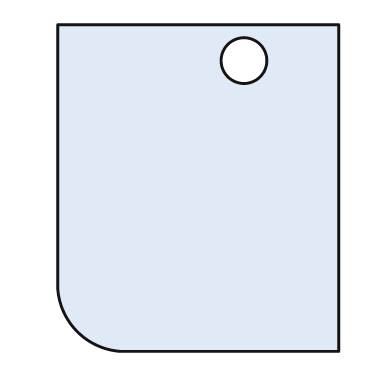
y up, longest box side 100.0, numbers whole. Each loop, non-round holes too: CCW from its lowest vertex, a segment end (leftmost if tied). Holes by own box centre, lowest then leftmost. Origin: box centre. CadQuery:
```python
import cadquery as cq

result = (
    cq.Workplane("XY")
    .moveTo(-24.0, -50.0)
    .lineTo(43.0, -50.0)
    .lineTo(43.0, 50.0)
    .lineTo(-43.0, 50.0)
    .lineTo(-43.0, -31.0)
    .threePointArc((-37.0, -44.0), (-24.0, -50.0))
    .close()
    .moveTo(14.0, 39.0)
    .circle(7.0)
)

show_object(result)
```